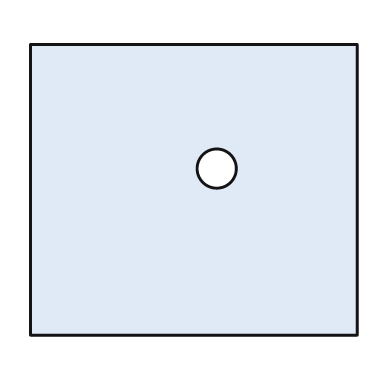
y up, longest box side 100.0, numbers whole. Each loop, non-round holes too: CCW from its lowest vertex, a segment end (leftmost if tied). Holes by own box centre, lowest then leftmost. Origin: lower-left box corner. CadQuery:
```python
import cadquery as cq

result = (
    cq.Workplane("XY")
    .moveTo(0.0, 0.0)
    .lineTo(100.0, 0.0)
    .lineTo(100.0, 89.0)
    .lineTo(0.0, 89.0)
    .close()
    .moveTo(57.0, 51.0)
    .circle(6.0)
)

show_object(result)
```